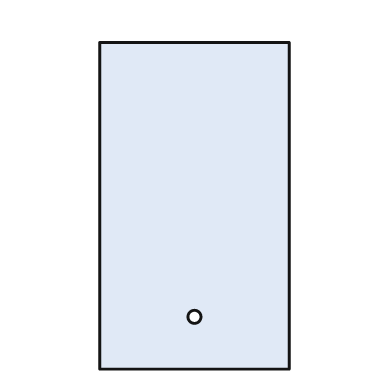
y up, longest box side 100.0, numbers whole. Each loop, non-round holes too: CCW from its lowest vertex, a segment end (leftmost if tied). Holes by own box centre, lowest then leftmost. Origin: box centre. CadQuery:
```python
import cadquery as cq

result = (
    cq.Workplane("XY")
    .moveTo(-29.0, -50.0)
    .lineTo(29.0, -50.0)
    .lineTo(29.0, 50.0)
    .lineTo(-29.0, 50.0)
    .close()
    .moveTo(0.0, -34.0)
    .circle(2.0)
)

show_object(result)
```